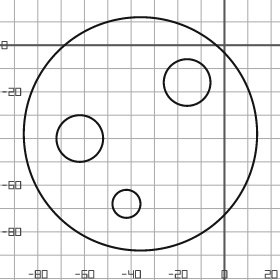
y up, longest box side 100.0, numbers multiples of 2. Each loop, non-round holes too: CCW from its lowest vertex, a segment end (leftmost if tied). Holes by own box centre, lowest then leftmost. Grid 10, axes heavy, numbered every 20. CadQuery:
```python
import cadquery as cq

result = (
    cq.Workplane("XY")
    .moveTo(-36.0, -38.0)
    .circle(50.0)
    .moveTo(-42.0, -68.0)
    .circle(6.0)
    .moveTo(-62.0, -40.0)
    .circle(10.0)
    .moveTo(-16.0, -16.0)
    .circle(10.0)
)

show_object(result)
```